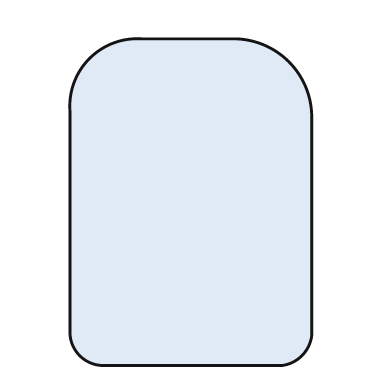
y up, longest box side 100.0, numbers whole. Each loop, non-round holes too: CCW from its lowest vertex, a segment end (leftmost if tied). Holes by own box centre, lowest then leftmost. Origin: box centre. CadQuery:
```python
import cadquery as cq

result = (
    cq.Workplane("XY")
    .moveTo(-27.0, -50.0)
    .lineTo(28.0, -50.0)
    .threePointArc((34.0, -47.0), (37.0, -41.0))
    .lineTo(37.0, 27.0)
    .threePointArc((30.0, 43.0), (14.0, 50.0))
    .lineTo(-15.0, 50.0)
    .threePointArc((-31.0, 44.0), (-37.0, 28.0))
    .lineTo(-37.0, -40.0)
    .threePointArc((-34.0, -47.0), (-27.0, -50.0))
    .close()
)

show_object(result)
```